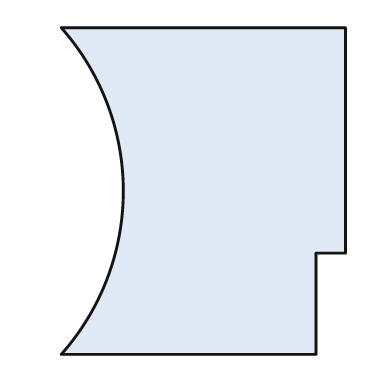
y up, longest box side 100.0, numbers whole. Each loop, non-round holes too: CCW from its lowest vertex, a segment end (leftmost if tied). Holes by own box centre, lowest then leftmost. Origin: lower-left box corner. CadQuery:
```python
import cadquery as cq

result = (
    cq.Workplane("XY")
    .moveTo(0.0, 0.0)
    .lineTo(78.0, 0.0)
    .lineTo(78.0, 31.0)
    .lineTo(87.0, 31.0)
    .lineTo(87.0, 100.0)
    .lineTo(0.0, 100.0)
    .threePointArc((19.0, 50.0), (0.0, 0.0))
    .close()
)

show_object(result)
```